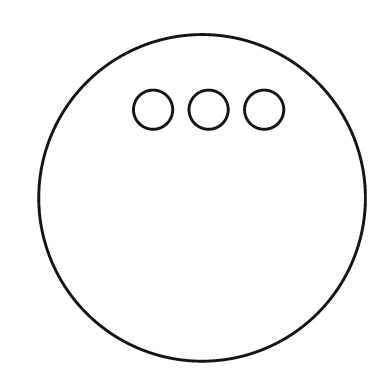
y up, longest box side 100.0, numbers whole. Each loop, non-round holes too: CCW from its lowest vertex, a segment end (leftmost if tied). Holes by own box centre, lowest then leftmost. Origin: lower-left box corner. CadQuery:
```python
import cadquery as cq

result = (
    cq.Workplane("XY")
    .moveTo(50.0, 50.0)
    .circle(50.0)
    .moveTo(35.0, 77.0)
    .circle(6.0)
    .moveTo(52.0, 77.0)
    .circle(6.0)
    .moveTo(69.0, 77.0)
    .circle(6.0)
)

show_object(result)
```